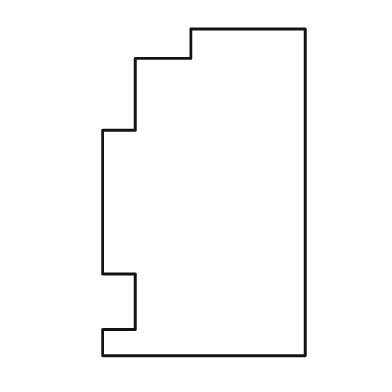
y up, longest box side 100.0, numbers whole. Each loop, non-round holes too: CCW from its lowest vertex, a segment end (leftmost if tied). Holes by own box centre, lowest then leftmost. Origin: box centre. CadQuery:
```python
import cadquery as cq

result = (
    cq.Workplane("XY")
    .moveTo(-31.0, -50.0)
    .lineTo(31.0, -50.0)
    .lineTo(31.0, 50.0)
    .lineTo(-4.0, 50.0)
    .lineTo(-4.0, 41.0)
    .lineTo(-21.0, 41.0)
    .lineTo(-21.0, 19.0)
    .lineTo(-31.0, 19.0)
    .lineTo(-31.0, -25.0)
    .lineTo(-21.0, -25.0)
    .lineTo(-21.0, -42.0)
    .lineTo(-31.0, -42.0)
    .close()
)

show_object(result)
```